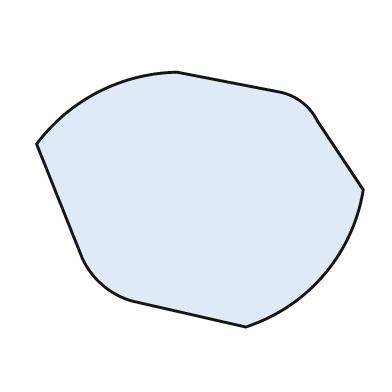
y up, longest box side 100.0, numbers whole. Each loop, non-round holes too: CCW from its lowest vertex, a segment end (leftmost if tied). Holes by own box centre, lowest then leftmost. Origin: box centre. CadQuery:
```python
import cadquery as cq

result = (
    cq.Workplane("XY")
    .moveTo(14.0, -39.0)
    .threePointArc((38.0, -23.0), (50.0, 3.0))
    .lineTo(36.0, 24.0)
    .threePointArc((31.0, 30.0), (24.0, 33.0))
    .lineTo(-7.0, 39.0)
    .threePointArc((-31.0, 33.0), (-50.0, 17.0))
    .lineTo(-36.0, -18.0)
    .threePointArc((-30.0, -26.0), (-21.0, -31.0))
    .close()
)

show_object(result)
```